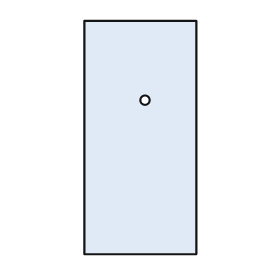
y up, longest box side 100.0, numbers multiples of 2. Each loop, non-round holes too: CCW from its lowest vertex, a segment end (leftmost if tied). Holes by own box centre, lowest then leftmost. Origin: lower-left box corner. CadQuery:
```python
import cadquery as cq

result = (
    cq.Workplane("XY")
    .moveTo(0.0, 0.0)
    .lineTo(48.0, 0.0)
    .lineTo(48.0, 100.0)
    .lineTo(0.0, 100.0)
    .close()
    .moveTo(26.0, 66.0)
    .circle(2.0)
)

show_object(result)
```